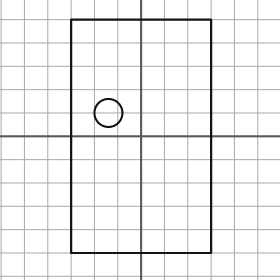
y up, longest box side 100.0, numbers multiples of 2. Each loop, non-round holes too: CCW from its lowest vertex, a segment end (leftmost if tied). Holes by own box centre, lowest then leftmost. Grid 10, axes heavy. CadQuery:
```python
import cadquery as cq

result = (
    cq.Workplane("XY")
    .moveTo(-30.0, -50.0)
    .lineTo(30.0, -50.0)
    .lineTo(30.0, 50.0)
    .lineTo(-30.0, 50.0)
    .close()
    .moveTo(-14.0, 10.0)
    .circle(6.0)
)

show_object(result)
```